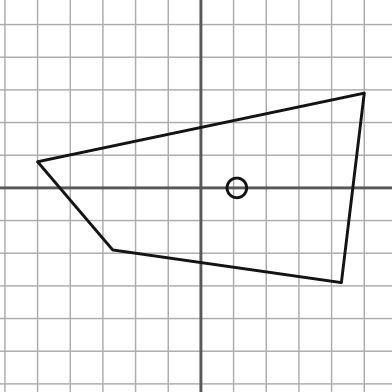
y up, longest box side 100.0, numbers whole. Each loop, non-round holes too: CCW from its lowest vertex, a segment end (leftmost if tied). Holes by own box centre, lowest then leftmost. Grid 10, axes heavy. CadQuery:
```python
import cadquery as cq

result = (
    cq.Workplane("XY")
    .moveTo(43.0, -29.0)
    .lineTo(50.0, 29.0)
    .lineTo(-50.0, 8.0)
    .lineTo(-27.0, -19.0)
    .close()
    .moveTo(11.0, 0.0)
    .circle(3.0)
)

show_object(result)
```